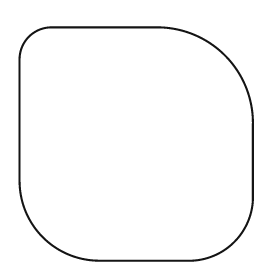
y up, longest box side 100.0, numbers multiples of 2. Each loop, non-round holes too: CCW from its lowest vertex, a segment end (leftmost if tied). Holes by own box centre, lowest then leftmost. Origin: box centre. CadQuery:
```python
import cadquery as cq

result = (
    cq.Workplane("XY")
    .moveTo(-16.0, -50.0)
    .lineTo(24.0, -50.0)
    .threePointArc((42.0, -42.0), (50.0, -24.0))
    .lineTo(50.0, 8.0)
    .threePointArc((38.0, 38.0), (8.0, 50.0))
    .lineTo(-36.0, 50.0)
    .threePointArc((-46.0, 46.0), (-50.0, 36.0))
    .lineTo(-50.0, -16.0)
    .threePointArc((-40.0, -40.0), (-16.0, -50.0))
    .close()
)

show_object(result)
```